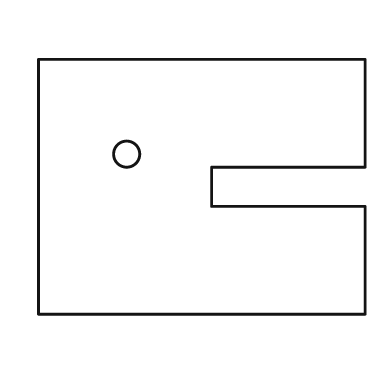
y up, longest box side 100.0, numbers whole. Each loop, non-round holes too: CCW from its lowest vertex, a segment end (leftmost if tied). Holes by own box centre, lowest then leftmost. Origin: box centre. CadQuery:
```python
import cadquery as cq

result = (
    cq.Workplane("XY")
    .moveTo(-50.0, -39.0)
    .lineTo(50.0, -39.0)
    .lineTo(50.0, -6.0)
    .lineTo(3.0, -6.0)
    .lineTo(3.0, 6.0)
    .lineTo(50.0, 6.0)
    .lineTo(50.0, 39.0)
    .lineTo(-50.0, 39.0)
    .close()
    .moveTo(-23.0, 10.0)
    .circle(4.0)
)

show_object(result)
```